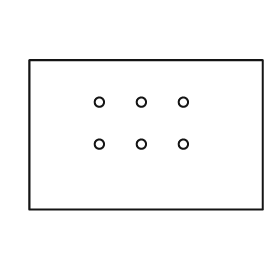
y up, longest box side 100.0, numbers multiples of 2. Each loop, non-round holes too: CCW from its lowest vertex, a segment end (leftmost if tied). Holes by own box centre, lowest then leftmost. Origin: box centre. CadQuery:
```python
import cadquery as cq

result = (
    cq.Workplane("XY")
    .moveTo(-50.0, -32.0)
    .lineTo(50.0, -32.0)
    .lineTo(50.0, 32.0)
    .lineTo(-50.0, 32.0)
    .close()
    .moveTo(-20.0, -4.0)
    .circle(2.0)
    .moveTo(-2.0, -4.0)
    .circle(2.0)
    .moveTo(16.0, -4.0)
    .circle(2.0)
    .moveTo(-20.0, 14.0)
    .circle(2.0)
    .moveTo(-2.0, 14.0)
    .circle(2.0)
    .moveTo(16.0, 14.0)
    .circle(2.0)
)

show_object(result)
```